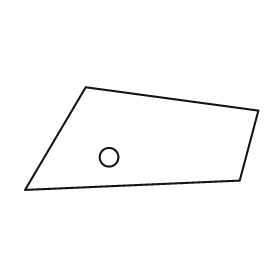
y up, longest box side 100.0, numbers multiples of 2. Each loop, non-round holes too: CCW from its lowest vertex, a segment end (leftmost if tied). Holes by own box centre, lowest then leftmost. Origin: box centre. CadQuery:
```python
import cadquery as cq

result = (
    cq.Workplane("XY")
    .moveTo(-50.0, -22.0)
    .lineTo(42.0, -18.0)
    .lineTo(50.0, 12.0)
    .lineTo(-24.0, 22.0)
    .close()
    .moveTo(-14.0, -8.0)
    .circle(4.0)
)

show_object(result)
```